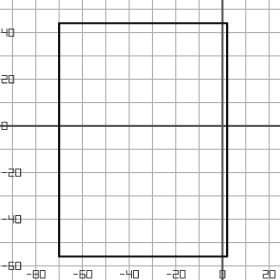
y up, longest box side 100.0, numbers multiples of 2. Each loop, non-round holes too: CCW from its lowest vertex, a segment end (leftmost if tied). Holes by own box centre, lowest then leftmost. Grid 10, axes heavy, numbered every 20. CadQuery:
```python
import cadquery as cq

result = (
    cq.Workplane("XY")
    .moveTo(-70.0, -56.0)
    .lineTo(2.0, -56.0)
    .lineTo(2.0, 44.0)
    .lineTo(-70.0, 44.0)
    .close()
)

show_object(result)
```